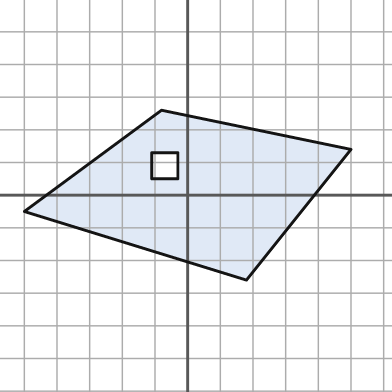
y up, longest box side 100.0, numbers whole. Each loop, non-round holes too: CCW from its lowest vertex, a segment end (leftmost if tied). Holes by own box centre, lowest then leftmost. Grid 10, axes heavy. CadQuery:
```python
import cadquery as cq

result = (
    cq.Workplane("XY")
    .moveTo(18.0, -26.0)
    .lineTo(50.0, 14.0)
    .lineTo(-8.0, 26.0)
    .lineTo(-50.0, -5.0)
    .close()
    .moveTo(-11.0, 5.0)
    .lineTo(-3.0, 5.0)
    .lineTo(-3.0, 13.0)
    .lineTo(-11.0, 13.0)
    .close()
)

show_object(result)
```